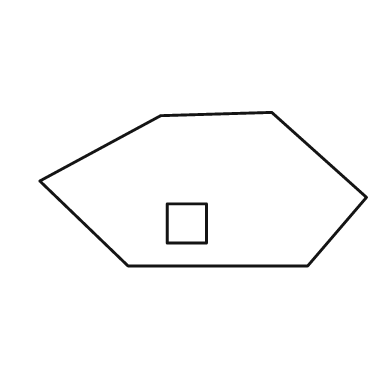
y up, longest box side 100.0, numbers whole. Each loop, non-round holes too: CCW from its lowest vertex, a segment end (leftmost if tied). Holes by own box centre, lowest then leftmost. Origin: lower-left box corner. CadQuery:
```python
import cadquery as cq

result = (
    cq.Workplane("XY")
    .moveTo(27.0, 0.0)
    .lineTo(82.0, 0.0)
    .lineTo(100.0, 21.0)
    .lineTo(71.0, 47.0)
    .lineTo(37.0, 46.0)
    .lineTo(0.0, 26.0)
    .close()
    .moveTo(39.0, 7.0)
    .lineTo(51.0, 7.0)
    .lineTo(51.0, 19.0)
    .lineTo(39.0, 19.0)
    .close()
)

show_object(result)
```